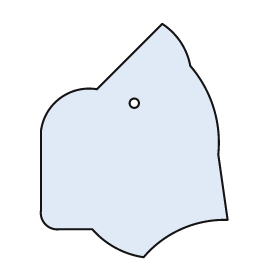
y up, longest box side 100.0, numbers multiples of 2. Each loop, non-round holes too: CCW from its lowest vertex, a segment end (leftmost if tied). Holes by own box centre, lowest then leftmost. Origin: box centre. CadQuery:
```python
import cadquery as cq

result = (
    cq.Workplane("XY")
    .moveTo(4.0, -50.0)
    .threePointArc((20.0, -38.0), (40.0, -34.0))
    .lineTo(36.0, -6.0)
    .threePointArc((34.0, 14.0), (24.0, 32.0))
    .threePointArc((20.0, 42.0), (12.0, 50.0))
    .lineTo(-16.0, 22.0)
    .threePointArc((-32.0, 18.0), (-40.0, 4.0))
    .lineTo(-40.0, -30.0)
    .threePointArc((-38.0, -36.0), (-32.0, -38.0))
    .lineTo(-18.0, -38.0)
    .threePointArc((-8.0, -46.0), (4.0, -50.0))
    .close()
    .moveTo(0.0, 16.0)
    .circle(2.0)
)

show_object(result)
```